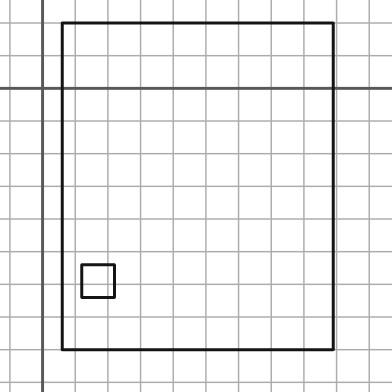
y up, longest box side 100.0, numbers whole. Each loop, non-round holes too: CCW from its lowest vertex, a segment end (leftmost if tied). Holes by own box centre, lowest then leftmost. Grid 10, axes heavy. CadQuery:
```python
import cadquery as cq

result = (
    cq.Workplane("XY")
    .moveTo(6.0, -80.0)
    .lineTo(89.0, -80.0)
    .lineTo(89.0, 20.0)
    .lineTo(6.0, 20.0)
    .close()
    .moveTo(12.0, -64.0)
    .lineTo(22.0, -64.0)
    .lineTo(22.0, -54.0)
    .lineTo(12.0, -54.0)
    .close()
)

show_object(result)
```